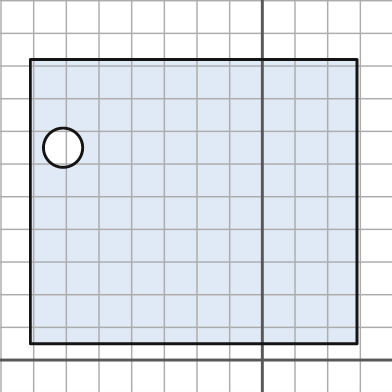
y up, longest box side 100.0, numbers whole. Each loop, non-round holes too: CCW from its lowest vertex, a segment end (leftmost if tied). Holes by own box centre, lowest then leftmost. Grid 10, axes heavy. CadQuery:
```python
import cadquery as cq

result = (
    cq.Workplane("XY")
    .moveTo(-71.0, 5.0)
    .lineTo(29.0, 5.0)
    .lineTo(29.0, 92.0)
    .lineTo(-71.0, 92.0)
    .close()
    .moveTo(-61.0, 65.0)
    .circle(6.0)
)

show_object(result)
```